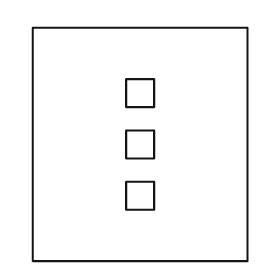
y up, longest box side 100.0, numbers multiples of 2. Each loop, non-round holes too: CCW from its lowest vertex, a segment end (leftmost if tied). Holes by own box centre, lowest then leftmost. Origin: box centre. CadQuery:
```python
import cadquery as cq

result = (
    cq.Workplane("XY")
    .moveTo(-46.0, -50.0)
    .lineTo(46.0, -50.0)
    .lineTo(46.0, 50.0)
    .lineTo(-46.0, 50.0)
    .close()
    .moveTo(-6.0, -28.0)
    .lineTo(6.0, -28.0)
    .lineTo(6.0, -16.0)
    .lineTo(-6.0, -16.0)
    .close()
    .moveTo(-6.0, -6.0)
    .lineTo(6.0, -6.0)
    .lineTo(6.0, 6.0)
    .lineTo(-6.0, 6.0)
    .close()
    .moveTo(-6.0, 16.0)
    .lineTo(6.0, 16.0)
    .lineTo(6.0, 28.0)
    .lineTo(-6.0, 28.0)
    .close()
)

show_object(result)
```